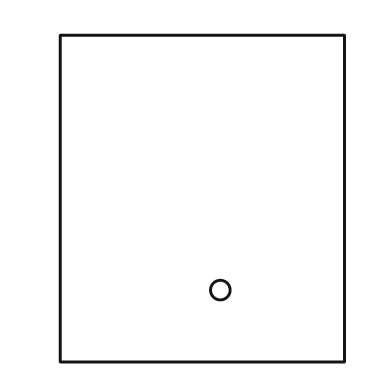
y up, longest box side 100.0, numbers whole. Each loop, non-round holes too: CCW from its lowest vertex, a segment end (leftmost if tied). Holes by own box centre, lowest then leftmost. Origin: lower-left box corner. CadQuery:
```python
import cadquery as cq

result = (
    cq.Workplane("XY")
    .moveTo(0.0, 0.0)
    .lineTo(87.0, 0.0)
    .lineTo(87.0, 100.0)
    .lineTo(0.0, 100.0)
    .close()
    .moveTo(49.0, 22.0)
    .circle(3.0)
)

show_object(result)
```